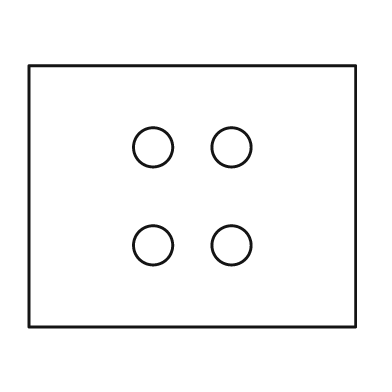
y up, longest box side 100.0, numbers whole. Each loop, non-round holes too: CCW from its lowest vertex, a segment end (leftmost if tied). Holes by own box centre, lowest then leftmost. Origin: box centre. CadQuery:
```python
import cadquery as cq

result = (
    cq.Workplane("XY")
    .moveTo(-50.0, -40.0)
    .lineTo(50.0, -40.0)
    .lineTo(50.0, 40.0)
    .lineTo(-50.0, 40.0)
    .close()
    .moveTo(-12.0, -15.0)
    .circle(6.0)
    .moveTo(12.0, -15.0)
    .circle(6.0)
    .moveTo(-12.0, 15.0)
    .circle(6.0)
    .moveTo(12.0, 15.0)
    .circle(6.0)
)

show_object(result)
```